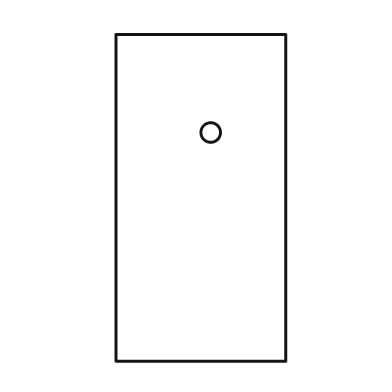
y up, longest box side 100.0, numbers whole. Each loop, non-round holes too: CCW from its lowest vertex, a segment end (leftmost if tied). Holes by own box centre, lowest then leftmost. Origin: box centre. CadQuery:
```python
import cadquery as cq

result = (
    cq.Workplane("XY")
    .moveTo(-26.0, -50.0)
    .lineTo(26.0, -50.0)
    .lineTo(26.0, 50.0)
    .lineTo(-26.0, 50.0)
    .close()
    .moveTo(3.0, 20.0)
    .circle(3.0)
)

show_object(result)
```